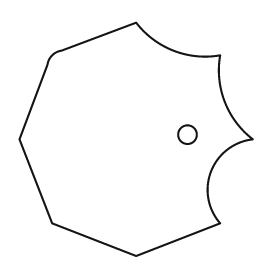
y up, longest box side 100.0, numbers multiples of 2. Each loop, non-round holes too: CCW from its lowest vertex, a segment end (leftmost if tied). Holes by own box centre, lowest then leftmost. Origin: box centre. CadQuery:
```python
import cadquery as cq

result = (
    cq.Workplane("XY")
    .moveTo(0.0, -50.0)
    .lineTo(36.0, -36.0)
    .threePointArc((32.0, -14.0), (50.0, 0.0))
    .threePointArc((38.0, 16.0), (36.0, 36.0))
    .threePointArc((16.0, 38.0), (0.0, 50.0))
    .lineTo(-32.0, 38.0)
    .threePointArc((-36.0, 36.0), (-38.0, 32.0))
    .lineTo(-50.0, 0.0)
    .lineTo(-36.0, -36.0)
    .close()
    .moveTo(22.0, 2.0)
    .circle(4.0)
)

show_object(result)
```